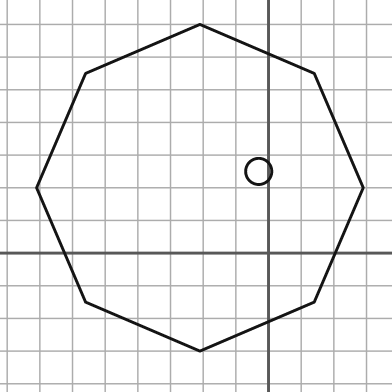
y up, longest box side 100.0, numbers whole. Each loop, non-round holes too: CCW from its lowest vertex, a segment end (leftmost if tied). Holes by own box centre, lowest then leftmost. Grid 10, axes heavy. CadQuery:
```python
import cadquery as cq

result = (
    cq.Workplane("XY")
    .moveTo(-21.0, -30.0)
    .lineTo(14.0, -15.0)
    .lineTo(29.0, 20.0)
    .lineTo(14.0, 55.0)
    .lineTo(-21.0, 70.0)
    .lineTo(-56.0, 55.0)
    .lineTo(-71.0, 20.0)
    .lineTo(-56.0, -15.0)
    .close()
    .moveTo(-3.0, 25.0)
    .circle(4.0)
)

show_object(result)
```